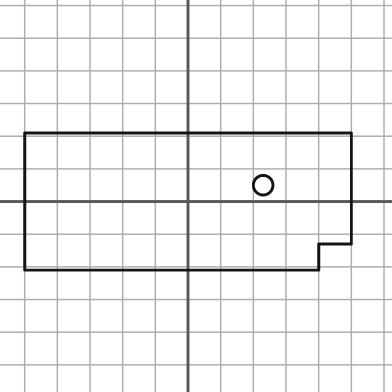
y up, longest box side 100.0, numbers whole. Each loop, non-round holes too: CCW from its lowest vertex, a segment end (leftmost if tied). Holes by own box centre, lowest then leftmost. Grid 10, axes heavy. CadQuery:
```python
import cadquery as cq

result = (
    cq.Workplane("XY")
    .moveTo(-50.0, -21.0)
    .lineTo(40.0, -21.0)
    .lineTo(40.0, -13.0)
    .lineTo(50.0, -13.0)
    .lineTo(50.0, 21.0)
    .lineTo(-50.0, 21.0)
    .close()
    .moveTo(23.0, 5.0)
    .circle(3.0)
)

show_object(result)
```